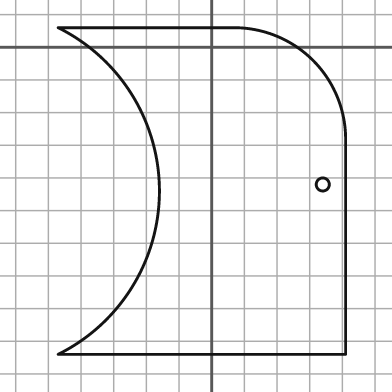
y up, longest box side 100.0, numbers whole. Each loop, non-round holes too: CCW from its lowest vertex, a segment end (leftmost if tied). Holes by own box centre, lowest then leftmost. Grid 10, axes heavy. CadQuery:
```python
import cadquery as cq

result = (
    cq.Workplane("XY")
    .moveTo(-47.0, -94.0)
    .lineTo(41.0, -94.0)
    .lineTo(41.0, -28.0)
    .threePointArc((31.0, -4.0), (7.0, 6.0))
    .lineTo(-47.0, 6.0)
    .threePointArc((-16.0, -44.0), (-47.0, -94.0))
    .close()
    .moveTo(34.0, -42.0)
    .circle(2.0)
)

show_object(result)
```